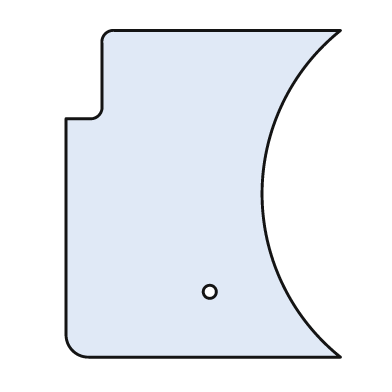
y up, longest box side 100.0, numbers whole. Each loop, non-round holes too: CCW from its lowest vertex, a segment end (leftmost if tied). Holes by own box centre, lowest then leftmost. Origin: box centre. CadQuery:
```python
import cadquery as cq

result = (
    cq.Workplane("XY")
    .moveTo(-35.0, -50.0)
    .lineTo(42.0, -50.0)
    .threePointArc((18.0, 0.0), (42.0, 50.0))
    .lineTo(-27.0, 50.0)
    .threePointArc((-30.0, 49.0), (-31.0, 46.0))
    .lineTo(-31.0, 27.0)
    .threePointArc((-32.0, 24.0), (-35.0, 23.0))
    .lineTo(-42.0, 23.0)
    .lineTo(-42.0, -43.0)
    .threePointArc((-40.0, -48.0), (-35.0, -50.0))
    .close()
    .moveTo(2.0, -30.0)
    .circle(2.0)
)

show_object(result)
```